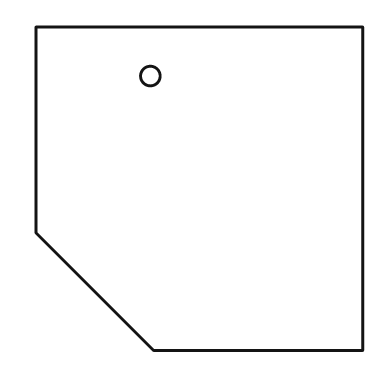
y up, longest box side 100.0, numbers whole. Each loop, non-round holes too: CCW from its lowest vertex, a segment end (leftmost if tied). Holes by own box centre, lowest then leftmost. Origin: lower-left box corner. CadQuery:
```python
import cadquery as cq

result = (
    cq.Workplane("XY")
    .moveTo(36.0, 0.0)
    .lineTo(100.0, 0.0)
    .lineTo(100.0, 99.0)
    .lineTo(0.0, 99.0)
    .lineTo(0.0, 36.0)
    .close()
    .moveTo(35.0, 84.0)
    .circle(3.0)
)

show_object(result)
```